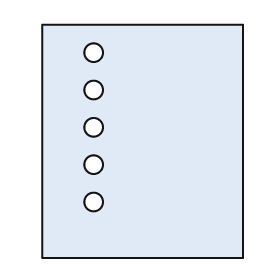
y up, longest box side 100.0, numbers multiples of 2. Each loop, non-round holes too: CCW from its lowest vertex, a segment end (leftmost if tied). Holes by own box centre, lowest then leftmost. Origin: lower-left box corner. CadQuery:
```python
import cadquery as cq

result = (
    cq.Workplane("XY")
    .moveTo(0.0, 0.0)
    .lineTo(86.0, 0.0)
    .lineTo(86.0, 100.0)
    .lineTo(0.0, 100.0)
    .close()
    .moveTo(22.0, 24.0)
    .circle(4.0)
    .moveTo(22.0, 40.0)
    .circle(4.0)
    .moveTo(22.0, 56.0)
    .circle(4.0)
    .moveTo(22.0, 72.0)
    .circle(4.0)
    .moveTo(22.0, 88.0)
    .circle(4.0)
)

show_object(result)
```